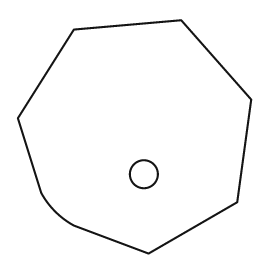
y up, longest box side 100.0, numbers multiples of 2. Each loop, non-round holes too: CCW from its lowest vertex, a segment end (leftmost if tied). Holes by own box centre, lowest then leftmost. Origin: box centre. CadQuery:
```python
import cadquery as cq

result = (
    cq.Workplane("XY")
    .moveTo(6.0, -50.0)
    .lineTo(44.0, -28.0)
    .lineTo(50.0, 16.0)
    .lineTo(20.0, 50.0)
    .lineTo(-26.0, 46.0)
    .lineTo(-50.0, 8.0)
    .lineTo(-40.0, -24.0)
    .threePointArc((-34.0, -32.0), (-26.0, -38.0))
    .close()
    .moveTo(4.0, -16.0)
    .circle(6.0)
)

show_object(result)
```